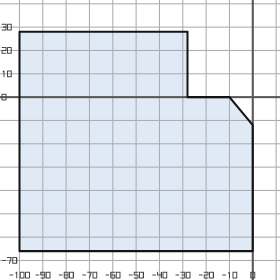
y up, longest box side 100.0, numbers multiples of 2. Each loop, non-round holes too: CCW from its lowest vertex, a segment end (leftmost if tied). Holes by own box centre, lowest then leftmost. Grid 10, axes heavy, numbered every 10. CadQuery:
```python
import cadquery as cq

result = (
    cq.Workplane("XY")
    .moveTo(-100.0, -66.0)
    .lineTo(0.0, -66.0)
    .lineTo(0.0, -12.0)
    .lineTo(-10.0, 0.0)
    .lineTo(-28.0, 0.0)
    .lineTo(-28.0, 28.0)
    .lineTo(-100.0, 28.0)
    .close()
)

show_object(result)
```